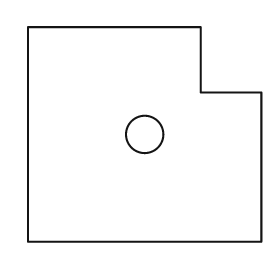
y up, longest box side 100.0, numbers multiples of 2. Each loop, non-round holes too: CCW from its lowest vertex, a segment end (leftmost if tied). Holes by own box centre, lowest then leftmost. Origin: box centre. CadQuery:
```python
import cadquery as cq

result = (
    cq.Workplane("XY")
    .moveTo(-50.0, -46.0)
    .lineTo(50.0, -46.0)
    .lineTo(50.0, 18.0)
    .lineTo(24.0, 18.0)
    .lineTo(24.0, 46.0)
    .lineTo(-50.0, 46.0)
    .close()
    .moveTo(0.0, 0.0)
    .circle(8.0)
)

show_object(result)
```